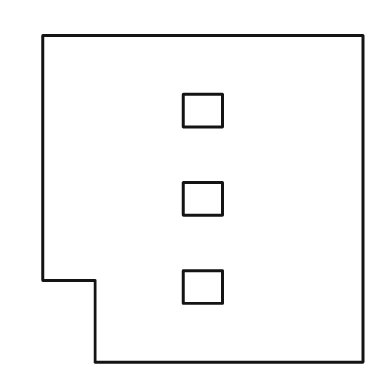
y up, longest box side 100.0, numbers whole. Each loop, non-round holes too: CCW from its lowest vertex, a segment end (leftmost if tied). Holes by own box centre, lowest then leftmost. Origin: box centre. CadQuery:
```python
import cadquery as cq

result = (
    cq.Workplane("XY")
    .moveTo(-33.0, -50.0)
    .lineTo(49.0, -50.0)
    .lineTo(49.0, 50.0)
    .lineTo(-49.0, 50.0)
    .lineTo(-49.0, -25.0)
    .lineTo(-33.0, -25.0)
    .close()
    .moveTo(-6.0, -32.0)
    .lineTo(6.0, -32.0)
    .lineTo(6.0, -22.0)
    .lineTo(-6.0, -22.0)
    .close()
    .moveTo(-6.0, -5.0)
    .lineTo(6.0, -5.0)
    .lineTo(6.0, 5.0)
    .lineTo(-6.0, 5.0)
    .close()
    .moveTo(-6.0, 22.0)
    .lineTo(6.0, 22.0)
    .lineTo(6.0, 32.0)
    .lineTo(-6.0, 32.0)
    .close()
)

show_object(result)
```